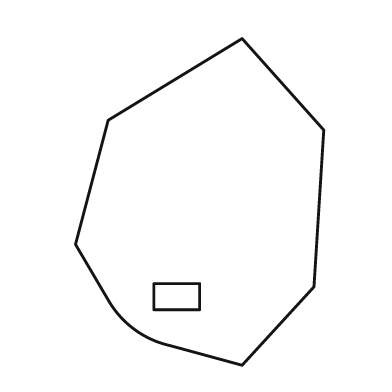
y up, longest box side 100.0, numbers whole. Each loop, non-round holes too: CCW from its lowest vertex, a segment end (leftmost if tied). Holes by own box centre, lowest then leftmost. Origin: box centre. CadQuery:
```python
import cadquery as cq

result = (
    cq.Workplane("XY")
    .moveTo(13.0, -50.0)
    .lineTo(35.0, -26.0)
    .lineTo(38.0, 22.0)
    .lineTo(13.0, 50.0)
    .lineTo(-28.0, 25.0)
    .lineTo(-38.0, -13.0)
    .lineTo(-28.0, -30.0)
    .threePointArc((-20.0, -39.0), (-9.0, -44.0))
    .close()
    .moveTo(-14.0, -33.0)
    .lineTo(0.0, -33.0)
    .lineTo(0.0, -25.0)
    .lineTo(-14.0, -25.0)
    .close()
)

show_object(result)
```